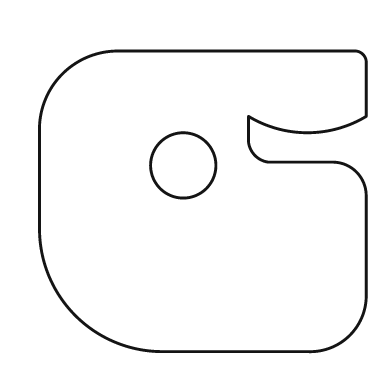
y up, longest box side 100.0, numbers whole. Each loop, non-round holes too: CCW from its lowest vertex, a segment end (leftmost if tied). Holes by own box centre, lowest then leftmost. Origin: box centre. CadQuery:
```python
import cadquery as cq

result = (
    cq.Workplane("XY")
    .moveTo(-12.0, -46.0)
    .lineTo(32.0, -46.0)
    .threePointArc((45.0, -41.0), (50.0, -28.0))
    .lineTo(50.0, 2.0)
    .threePointArc((47.0, 9.0), (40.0, 12.0))
    .lineTo(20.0, 12.0)
    .threePointArc((16.0, 14.0), (14.0, 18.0))
    .lineTo(14.0, 26.0)
    .threePointArc((32.0, 21.0), (50.0, 26.0))
    .lineTo(50.0, 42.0)
    .threePointArc((49.0, 45.0), (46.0, 46.0))
    .lineTo(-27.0, 46.0)
    .threePointArc((-43.0, 39.0), (-50.0, 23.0))
    .lineTo(-50.0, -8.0)
    .threePointArc((-39.0, -35.0), (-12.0, -46.0))
    .close()
    .moveTo(-6.0, 11.0)
    .circle(10.0)
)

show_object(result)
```